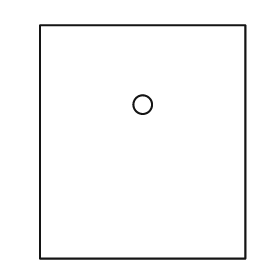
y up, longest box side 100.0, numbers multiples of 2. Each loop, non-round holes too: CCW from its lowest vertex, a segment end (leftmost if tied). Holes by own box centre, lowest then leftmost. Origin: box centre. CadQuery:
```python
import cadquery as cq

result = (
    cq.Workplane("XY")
    .moveTo(-44.0, -50.0)
    .lineTo(44.0, -50.0)
    .lineTo(44.0, 50.0)
    .lineTo(-44.0, 50.0)
    .close()
    .moveTo(0.0, 16.0)
    .circle(4.0)
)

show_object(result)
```